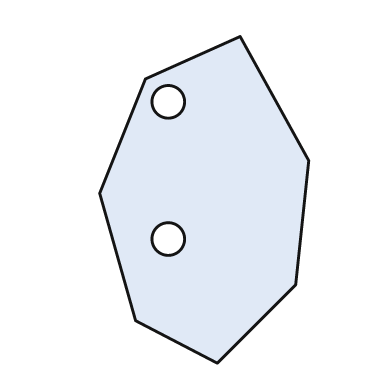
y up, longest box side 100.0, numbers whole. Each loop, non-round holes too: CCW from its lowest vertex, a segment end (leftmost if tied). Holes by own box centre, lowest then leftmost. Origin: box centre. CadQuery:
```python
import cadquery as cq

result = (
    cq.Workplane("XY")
    .moveTo(4.0, -50.0)
    .lineTo(28.0, -26.0)
    .lineTo(32.0, 12.0)
    .lineTo(11.0, 50.0)
    .lineTo(-18.0, 37.0)
    .lineTo(-32.0, 2.0)
    .lineTo(-21.0, -37.0)
    .close()
    .moveTo(-11.0, -12.0)
    .circle(5.0)
    .moveTo(-11.0, 30.0)
    .circle(5.0)
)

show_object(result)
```